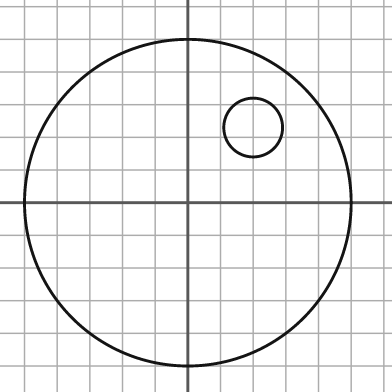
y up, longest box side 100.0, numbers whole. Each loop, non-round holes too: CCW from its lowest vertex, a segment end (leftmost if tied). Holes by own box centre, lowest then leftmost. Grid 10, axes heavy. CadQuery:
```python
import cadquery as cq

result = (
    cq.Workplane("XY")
    .moveTo(0.0, 0.0)
    .circle(50.0)
    .moveTo(20.0, 23.0)
    .circle(9.0)
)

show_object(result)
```